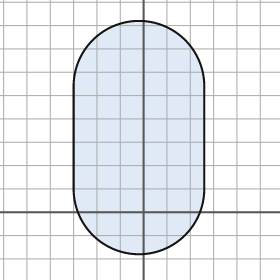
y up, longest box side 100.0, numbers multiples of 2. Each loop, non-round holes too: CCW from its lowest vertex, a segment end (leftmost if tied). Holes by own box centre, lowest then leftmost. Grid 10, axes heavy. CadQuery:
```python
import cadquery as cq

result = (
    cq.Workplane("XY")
    .moveTo(-30.0, 10.0)
    .threePointArc((-2.0, -18.0), (26.0, 10.0))
    .lineTo(26.0, 54.0)
    .threePointArc((-2.0, 82.0), (-30.0, 54.0))
    .close()
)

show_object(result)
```